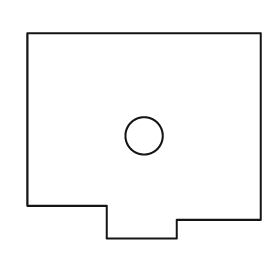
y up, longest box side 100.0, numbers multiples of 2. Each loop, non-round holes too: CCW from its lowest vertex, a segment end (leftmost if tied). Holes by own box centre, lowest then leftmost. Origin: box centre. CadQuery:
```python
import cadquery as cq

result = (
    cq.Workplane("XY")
    .moveTo(-16.0, -44.0)
    .lineTo(14.0, -44.0)
    .lineTo(14.0, -36.0)
    .lineTo(50.0, -36.0)
    .lineTo(50.0, 44.0)
    .lineTo(-50.0, 44.0)
    .lineTo(-50.0, -30.0)
    .lineTo(-16.0, -30.0)
    .close()
    .moveTo(0.0, 0.0)
    .circle(8.0)
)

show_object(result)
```